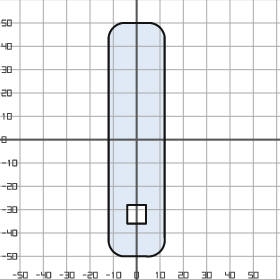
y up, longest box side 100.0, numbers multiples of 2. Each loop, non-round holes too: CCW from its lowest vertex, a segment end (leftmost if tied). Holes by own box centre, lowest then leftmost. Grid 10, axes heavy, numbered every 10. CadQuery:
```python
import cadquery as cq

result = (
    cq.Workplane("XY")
    .moveTo(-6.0, -50.0)
    .lineTo(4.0, -50.0)
    .threePointArc((10.0, -48.0), (12.0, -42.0))
    .lineTo(12.0, 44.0)
    .threePointArc((10.0, 48.0), (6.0, 50.0))
    .lineTo(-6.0, 50.0)
    .threePointArc((-10.0, 48.0), (-12.0, 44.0))
    .lineTo(-12.0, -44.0)
    .threePointArc((-10.0, -48.0), (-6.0, -50.0))
    .close()
    .moveTo(-4.0, -36.0)
    .lineTo(4.0, -36.0)
    .lineTo(4.0, -28.0)
    .lineTo(-4.0, -28.0)
    .close()
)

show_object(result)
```